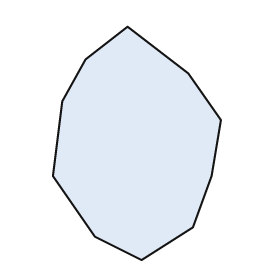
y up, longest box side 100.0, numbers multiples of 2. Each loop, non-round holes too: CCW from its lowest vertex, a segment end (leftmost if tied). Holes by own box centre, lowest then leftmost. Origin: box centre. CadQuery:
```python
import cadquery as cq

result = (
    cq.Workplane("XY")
    .moveTo(2.0, -50.0)
    .lineTo(24.0, -36.0)
    .lineTo(32.0, -14.0)
    .lineTo(36.0, 10.0)
    .lineTo(22.0, 30.0)
    .lineTo(-4.0, 50.0)
    .lineTo(-22.0, 36.0)
    .lineTo(-32.0, 18.0)
    .lineTo(-36.0, -14.0)
    .lineTo(-18.0, -40.0)
    .close()
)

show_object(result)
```